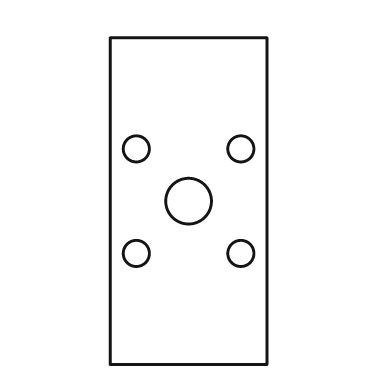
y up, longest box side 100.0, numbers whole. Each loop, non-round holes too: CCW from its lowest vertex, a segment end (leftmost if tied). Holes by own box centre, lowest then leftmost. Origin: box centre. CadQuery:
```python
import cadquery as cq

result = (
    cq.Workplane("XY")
    .moveTo(-24.0, -50.0)
    .lineTo(24.0, -50.0)
    .lineTo(24.0, 50.0)
    .lineTo(-24.0, 50.0)
    .close()
    .moveTo(-16.0, -16.0)
    .circle(4.0)
    .moveTo(16.0, -16.0)
    .circle(4.0)
    .moveTo(0.0, 0.0)
    .circle(7.0)
    .moveTo(-16.0, 16.0)
    .circle(4.0)
    .moveTo(16.0, 16.0)
    .circle(4.0)
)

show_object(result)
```